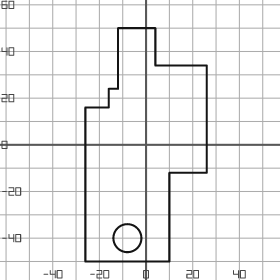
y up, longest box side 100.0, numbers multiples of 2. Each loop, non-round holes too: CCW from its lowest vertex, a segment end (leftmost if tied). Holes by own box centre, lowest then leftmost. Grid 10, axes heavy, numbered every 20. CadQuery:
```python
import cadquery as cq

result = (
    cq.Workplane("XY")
    .moveTo(-26.0, -50.0)
    .lineTo(10.0, -50.0)
    .lineTo(10.0, -12.0)
    .lineTo(26.0, -12.0)
    .lineTo(26.0, 34.0)
    .lineTo(4.0, 34.0)
    .lineTo(4.0, 50.0)
    .lineTo(-12.0, 50.0)
    .lineTo(-12.0, 24.0)
    .lineTo(-16.0, 24.0)
    .lineTo(-16.0, 16.0)
    .lineTo(-26.0, 16.0)
    .close()
    .moveTo(-8.0, -40.0)
    .circle(6.0)
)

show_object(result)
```